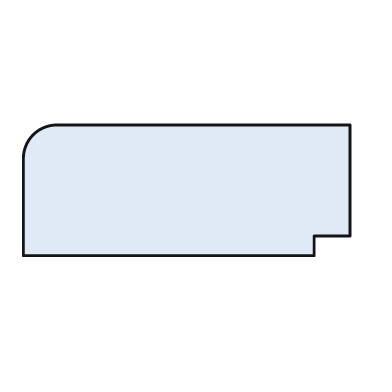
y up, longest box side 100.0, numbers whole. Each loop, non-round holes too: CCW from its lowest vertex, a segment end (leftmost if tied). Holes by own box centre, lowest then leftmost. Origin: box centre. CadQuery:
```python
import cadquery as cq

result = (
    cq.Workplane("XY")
    .moveTo(-50.0, -20.0)
    .lineTo(39.0, -20.0)
    .lineTo(39.0, -14.0)
    .lineTo(50.0, -14.0)
    .lineTo(50.0, 20.0)
    .lineTo(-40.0, 20.0)
    .threePointArc((-47.0, 17.0), (-50.0, 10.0))
    .close()
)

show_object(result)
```